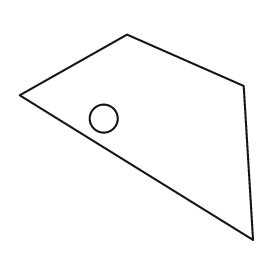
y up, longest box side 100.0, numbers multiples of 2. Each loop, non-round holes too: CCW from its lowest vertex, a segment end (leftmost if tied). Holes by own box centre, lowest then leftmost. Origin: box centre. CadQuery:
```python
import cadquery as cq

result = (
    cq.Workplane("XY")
    .moveTo(50.0, -44.0)
    .lineTo(46.0, 22.0)
    .lineTo(-4.0, 44.0)
    .lineTo(-50.0, 18.0)
    .close()
    .moveTo(-14.0, 8.0)
    .circle(6.0)
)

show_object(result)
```